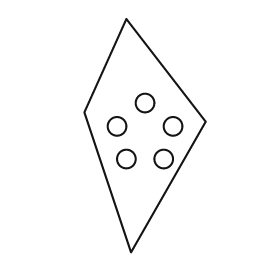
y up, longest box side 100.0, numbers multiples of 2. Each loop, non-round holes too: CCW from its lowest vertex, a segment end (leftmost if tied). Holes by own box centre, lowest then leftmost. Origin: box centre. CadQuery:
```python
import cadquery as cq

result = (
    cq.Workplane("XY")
    .moveTo(-6.0, -50.0)
    .lineTo(26.0, 6.0)
    .lineTo(-8.0, 50.0)
    .lineTo(-26.0, 10.0)
    .close()
    .moveTo(-8.0, -10.0)
    .circle(4.0)
    .moveTo(8.0, -10.0)
    .circle(4.0)
    .moveTo(-12.0, 4.0)
    .circle(4.0)
    .moveTo(12.0, 4.0)
    .circle(4.0)
    .moveTo(0.0, 14.0)
    .circle(4.0)
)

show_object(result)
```